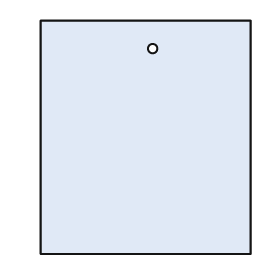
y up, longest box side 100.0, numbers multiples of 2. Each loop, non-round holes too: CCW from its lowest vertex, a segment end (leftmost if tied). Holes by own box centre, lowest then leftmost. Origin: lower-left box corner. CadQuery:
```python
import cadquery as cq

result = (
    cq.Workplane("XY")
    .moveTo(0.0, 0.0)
    .lineTo(90.0, 0.0)
    .lineTo(90.0, 100.0)
    .lineTo(0.0, 100.0)
    .close()
    .moveTo(48.0, 88.0)
    .circle(2.0)
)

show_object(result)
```